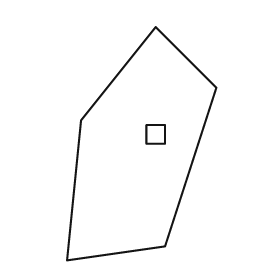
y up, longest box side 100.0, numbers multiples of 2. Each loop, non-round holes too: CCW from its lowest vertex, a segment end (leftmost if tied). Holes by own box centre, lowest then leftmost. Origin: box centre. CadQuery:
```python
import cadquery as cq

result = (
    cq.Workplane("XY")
    .moveTo(-32.0, -50.0)
    .lineTo(10.0, -44.0)
    .lineTo(32.0, 24.0)
    .lineTo(6.0, 50.0)
    .lineTo(-26.0, 10.0)
    .close()
    .moveTo(2.0, 0.0)
    .lineTo(10.0, 0.0)
    .lineTo(10.0, 8.0)
    .lineTo(2.0, 8.0)
    .close()
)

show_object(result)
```